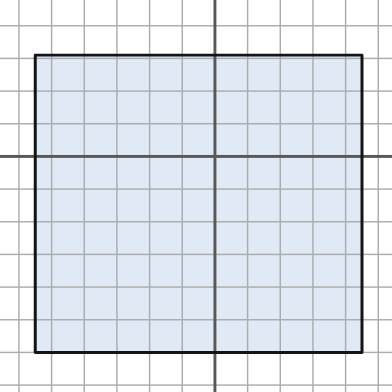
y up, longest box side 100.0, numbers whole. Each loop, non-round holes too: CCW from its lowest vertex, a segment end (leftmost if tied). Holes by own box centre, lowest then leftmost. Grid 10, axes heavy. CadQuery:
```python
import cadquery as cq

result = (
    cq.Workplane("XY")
    .moveTo(-55.0, -60.0)
    .lineTo(45.0, -60.0)
    .lineTo(45.0, 31.0)
    .lineTo(-55.0, 31.0)
    .close()
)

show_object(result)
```